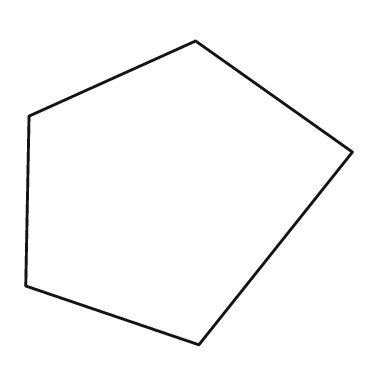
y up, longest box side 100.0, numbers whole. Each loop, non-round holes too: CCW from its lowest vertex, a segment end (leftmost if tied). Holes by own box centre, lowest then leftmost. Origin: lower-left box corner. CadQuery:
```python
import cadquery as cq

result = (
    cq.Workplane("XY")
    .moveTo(53.0, 0.0)
    .lineTo(100.0, 59.0)
    .lineTo(52.0, 93.0)
    .lineTo(1.0, 70.0)
    .lineTo(0.0, 18.0)
    .close()
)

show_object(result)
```